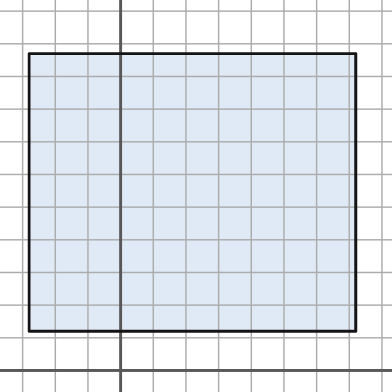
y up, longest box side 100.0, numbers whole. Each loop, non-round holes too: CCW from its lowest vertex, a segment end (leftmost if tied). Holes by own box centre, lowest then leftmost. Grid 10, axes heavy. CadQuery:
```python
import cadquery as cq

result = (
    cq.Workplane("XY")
    .moveTo(-28.0, 12.0)
    .lineTo(72.0, 12.0)
    .lineTo(72.0, 97.0)
    .lineTo(-28.0, 97.0)
    .close()
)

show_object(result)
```